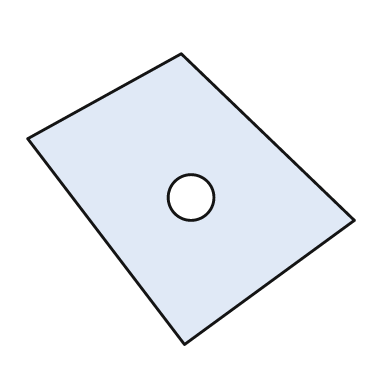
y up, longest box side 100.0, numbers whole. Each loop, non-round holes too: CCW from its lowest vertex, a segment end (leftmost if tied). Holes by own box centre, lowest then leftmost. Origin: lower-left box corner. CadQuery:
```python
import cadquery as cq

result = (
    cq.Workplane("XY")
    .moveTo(48.0, 0.0)
    .lineTo(100.0, 38.0)
    .lineTo(47.0, 89.0)
    .lineTo(0.0, 63.0)
    .close()
    .moveTo(50.0, 45.0)
    .circle(7.0)
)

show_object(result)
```